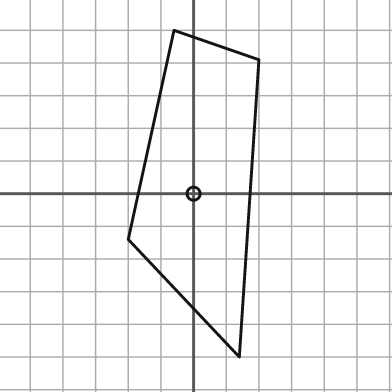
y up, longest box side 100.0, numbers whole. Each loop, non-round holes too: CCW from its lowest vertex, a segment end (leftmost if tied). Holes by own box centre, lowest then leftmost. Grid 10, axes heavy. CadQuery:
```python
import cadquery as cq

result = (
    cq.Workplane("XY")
    .moveTo(14.0, -50.0)
    .lineTo(20.0, 41.0)
    .lineTo(-6.0, 50.0)
    .lineTo(-20.0, -14.0)
    .close()
    .moveTo(0.0, 0.0)
    .circle(2.0)
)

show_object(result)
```